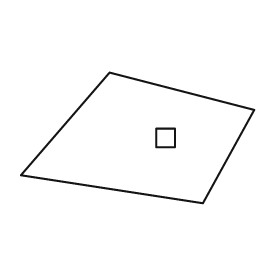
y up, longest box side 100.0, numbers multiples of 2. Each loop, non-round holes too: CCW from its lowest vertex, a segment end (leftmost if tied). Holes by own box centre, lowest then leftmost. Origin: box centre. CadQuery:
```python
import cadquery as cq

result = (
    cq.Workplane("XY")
    .moveTo(28.0, -28.0)
    .lineTo(50.0, 12.0)
    .lineTo(-12.0, 28.0)
    .lineTo(-50.0, -16.0)
    .close()
    .moveTo(8.0, -4.0)
    .lineTo(16.0, -4.0)
    .lineTo(16.0, 4.0)
    .lineTo(8.0, 4.0)
    .close()
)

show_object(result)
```